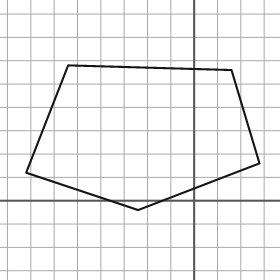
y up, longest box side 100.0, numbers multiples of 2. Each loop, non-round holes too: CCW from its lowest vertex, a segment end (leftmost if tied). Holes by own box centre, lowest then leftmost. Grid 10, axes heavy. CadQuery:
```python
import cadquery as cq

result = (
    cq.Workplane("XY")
    .moveTo(-24.0, -4.0)
    .lineTo(28.0, 16.0)
    .lineTo(16.0, 56.0)
    .lineTo(-54.0, 58.0)
    .lineTo(-72.0, 12.0)
    .close()
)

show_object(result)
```